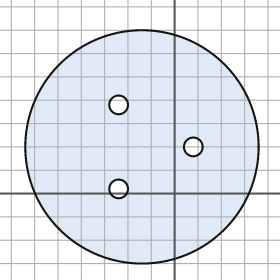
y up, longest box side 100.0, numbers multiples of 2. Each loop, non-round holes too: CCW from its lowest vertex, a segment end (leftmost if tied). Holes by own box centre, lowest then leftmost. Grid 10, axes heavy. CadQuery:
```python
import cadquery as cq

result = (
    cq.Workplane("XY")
    .moveTo(-14.0, 20.0)
    .circle(50.0)
    .moveTo(-24.0, 2.0)
    .circle(4.0)
    .moveTo(8.0, 20.0)
    .circle(4.0)
    .moveTo(-24.0, 38.0)
    .circle(4.0)
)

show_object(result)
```